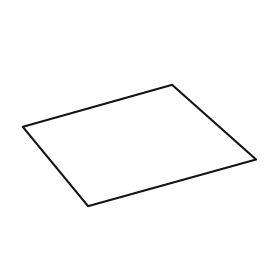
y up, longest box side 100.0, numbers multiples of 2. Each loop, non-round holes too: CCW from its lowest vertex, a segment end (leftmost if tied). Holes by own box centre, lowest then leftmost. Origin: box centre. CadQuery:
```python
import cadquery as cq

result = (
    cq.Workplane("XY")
    .moveTo(-22.0, -26.0)
    .lineTo(50.0, -6.0)
    .lineTo(14.0, 26.0)
    .lineTo(-50.0, 8.0)
    .close()
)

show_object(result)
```